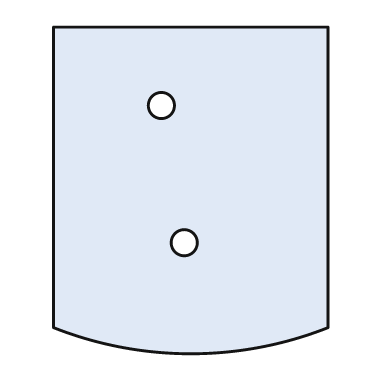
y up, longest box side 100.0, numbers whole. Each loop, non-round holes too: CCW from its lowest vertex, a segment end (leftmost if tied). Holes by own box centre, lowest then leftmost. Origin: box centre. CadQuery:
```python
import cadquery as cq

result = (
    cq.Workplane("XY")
    .moveTo(-42.0, -42.0)
    .threePointArc((0.0, -50.0), (42.0, -42.0))
    .lineTo(42.0, 50.0)
    .lineTo(-42.0, 50.0)
    .close()
    .moveTo(-2.0, -16.0)
    .circle(4.0)
    .moveTo(-9.0, 26.0)
    .circle(4.0)
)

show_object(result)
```